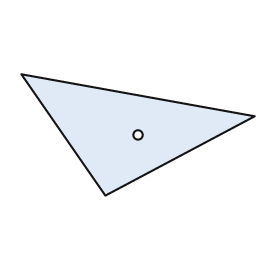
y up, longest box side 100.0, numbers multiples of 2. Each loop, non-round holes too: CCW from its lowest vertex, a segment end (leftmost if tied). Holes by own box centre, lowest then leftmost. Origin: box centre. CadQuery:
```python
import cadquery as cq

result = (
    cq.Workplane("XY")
    .moveTo(-14.0, -26.0)
    .lineTo(50.0, 8.0)
    .lineTo(-50.0, 26.0)
    .close()
    .moveTo(0.0, 0.0)
    .circle(2.0)
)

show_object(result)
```